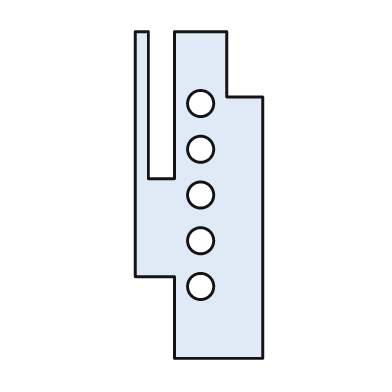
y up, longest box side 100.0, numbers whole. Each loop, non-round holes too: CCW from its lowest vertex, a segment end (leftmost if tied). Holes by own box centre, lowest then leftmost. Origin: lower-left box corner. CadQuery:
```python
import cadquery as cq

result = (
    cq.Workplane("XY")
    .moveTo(12.0, 0.0)
    .lineTo(39.0, 0.0)
    .lineTo(39.0, 80.0)
    .lineTo(28.0, 80.0)
    .lineTo(28.0, 100.0)
    .lineTo(12.0, 100.0)
    .lineTo(12.0, 55.0)
    .lineTo(4.0, 55.0)
    .lineTo(4.0, 100.0)
    .lineTo(0.0, 100.0)
    .lineTo(0.0, 25.0)
    .lineTo(12.0, 25.0)
    .close()
    .moveTo(20.0, 22.0)
    .circle(4.0)
    .moveTo(20.0, 36.0)
    .circle(4.0)
    .moveTo(20.0, 50.0)
    .circle(4.0)
    .moveTo(20.0, 64.0)
    .circle(4.0)
    .moveTo(20.0, 78.0)
    .circle(4.0)
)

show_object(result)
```